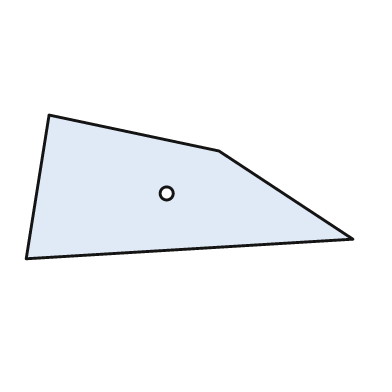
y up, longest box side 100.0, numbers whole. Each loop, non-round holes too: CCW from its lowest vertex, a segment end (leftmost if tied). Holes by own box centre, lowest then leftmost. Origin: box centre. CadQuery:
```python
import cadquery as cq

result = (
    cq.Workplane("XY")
    .moveTo(-50.0, -22.0)
    .lineTo(50.0, -16.0)
    .lineTo(9.0, 11.0)
    .lineTo(-43.0, 22.0)
    .close()
    .moveTo(-7.0, -2.0)
    .circle(2.0)
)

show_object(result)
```